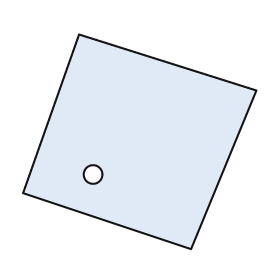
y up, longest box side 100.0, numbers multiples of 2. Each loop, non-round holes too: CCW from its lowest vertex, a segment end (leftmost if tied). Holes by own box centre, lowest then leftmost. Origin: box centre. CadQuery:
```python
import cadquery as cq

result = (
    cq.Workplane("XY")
    .moveTo(22.0, -46.0)
    .lineTo(50.0, 22.0)
    .lineTo(-26.0, 46.0)
    .lineTo(-50.0, -22.0)
    .close()
    .moveTo(-20.0, -14.0)
    .circle(4.0)
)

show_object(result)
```